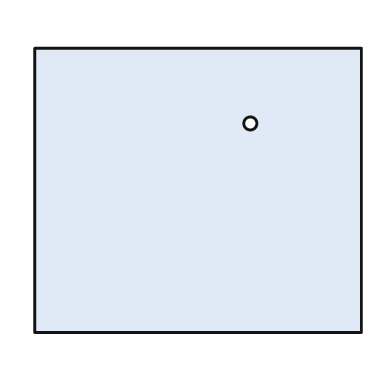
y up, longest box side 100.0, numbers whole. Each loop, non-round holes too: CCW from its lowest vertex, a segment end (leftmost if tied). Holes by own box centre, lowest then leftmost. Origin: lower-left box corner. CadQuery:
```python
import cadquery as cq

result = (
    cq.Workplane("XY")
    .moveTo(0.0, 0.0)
    .lineTo(100.0, 0.0)
    .lineTo(100.0, 87.0)
    .lineTo(0.0, 87.0)
    .close()
    .moveTo(66.0, 64.0)
    .circle(2.0)
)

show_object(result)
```